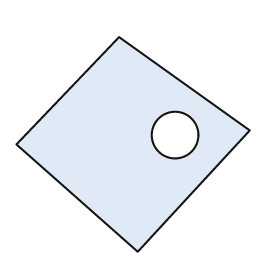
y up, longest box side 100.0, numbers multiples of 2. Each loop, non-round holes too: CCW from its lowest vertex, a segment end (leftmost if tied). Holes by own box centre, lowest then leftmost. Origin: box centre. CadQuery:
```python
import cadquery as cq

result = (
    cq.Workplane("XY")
    .moveTo(2.0, -46.0)
    .lineTo(50.0, 6.0)
    .lineTo(-6.0, 46.0)
    .lineTo(-50.0, 0.0)
    .close()
    .moveTo(18.0, 4.0)
    .circle(10.0)
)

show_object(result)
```